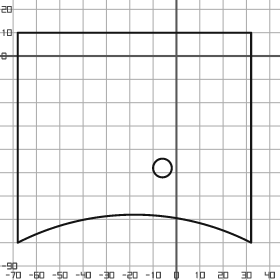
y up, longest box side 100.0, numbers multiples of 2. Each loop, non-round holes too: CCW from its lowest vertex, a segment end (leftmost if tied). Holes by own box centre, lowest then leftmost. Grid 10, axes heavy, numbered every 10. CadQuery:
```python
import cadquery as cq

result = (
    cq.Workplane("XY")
    .moveTo(-68.0, -80.0)
    .threePointArc((-18.0, -68.0), (32.0, -80.0))
    .lineTo(32.0, 10.0)
    .lineTo(-68.0, 10.0)
    .close()
    .moveTo(-6.0, -48.0)
    .circle(4.0)
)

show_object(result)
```